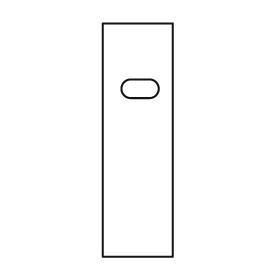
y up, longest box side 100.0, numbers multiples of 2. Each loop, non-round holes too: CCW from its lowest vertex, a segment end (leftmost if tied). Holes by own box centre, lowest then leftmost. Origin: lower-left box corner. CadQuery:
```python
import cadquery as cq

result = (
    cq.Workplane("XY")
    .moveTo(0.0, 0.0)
    .lineTo(30.0, 0.0)
    .lineTo(30.0, 100.0)
    .lineTo(0.0, 100.0)
    .close()
    .moveTo(12.0, 68.0)
    .lineTo(20.0, 68.0)
    .threePointArc((24.0, 72.0), (20.0, 76.0))
    .lineTo(12.0, 76.0)
    .threePointArc((8.0, 72.0), (12.0, 68.0))
    .close()
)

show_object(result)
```